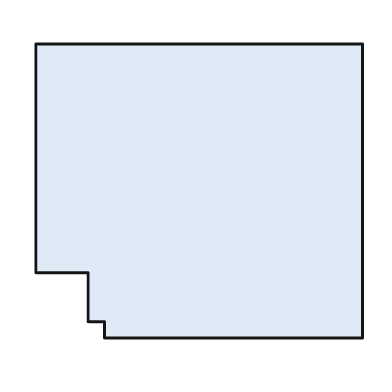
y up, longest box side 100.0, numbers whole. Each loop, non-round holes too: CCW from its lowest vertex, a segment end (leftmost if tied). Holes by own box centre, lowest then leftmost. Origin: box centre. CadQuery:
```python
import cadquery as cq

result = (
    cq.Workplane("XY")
    .moveTo(-29.0, -45.0)
    .lineTo(50.0, -45.0)
    .lineTo(50.0, 45.0)
    .lineTo(-50.0, 45.0)
    .lineTo(-50.0, -25.0)
    .lineTo(-34.0, -25.0)
    .lineTo(-34.0, -40.0)
    .lineTo(-29.0, -40.0)
    .close()
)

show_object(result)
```